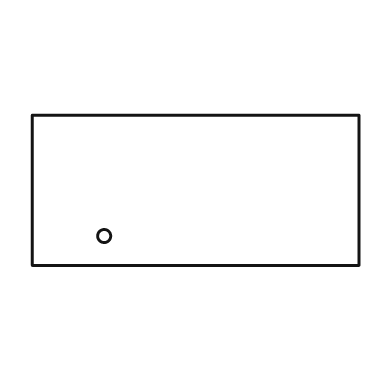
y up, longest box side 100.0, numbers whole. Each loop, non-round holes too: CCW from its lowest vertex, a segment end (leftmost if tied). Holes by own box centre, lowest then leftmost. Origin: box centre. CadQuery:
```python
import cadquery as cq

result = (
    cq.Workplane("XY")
    .moveTo(-50.0, -23.0)
    .lineTo(50.0, -23.0)
    .lineTo(50.0, 23.0)
    .lineTo(-50.0, 23.0)
    .close()
    .moveTo(-28.0, -14.0)
    .circle(2.0)
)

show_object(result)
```